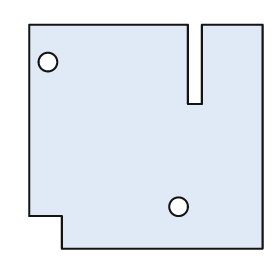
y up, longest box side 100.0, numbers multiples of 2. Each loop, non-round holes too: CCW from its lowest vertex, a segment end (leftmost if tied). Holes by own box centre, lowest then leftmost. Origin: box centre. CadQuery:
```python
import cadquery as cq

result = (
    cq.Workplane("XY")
    .moveTo(-36.0, -48.0)
    .lineTo(50.0, -48.0)
    .lineTo(50.0, 48.0)
    .lineTo(24.0, 48.0)
    .lineTo(24.0, 14.0)
    .lineTo(18.0, 14.0)
    .lineTo(18.0, 48.0)
    .lineTo(-50.0, 48.0)
    .lineTo(-50.0, -34.0)
    .lineTo(-36.0, -34.0)
    .close()
    .moveTo(14.0, -30.0)
    .circle(4.0)
    .moveTo(-42.0, 32.0)
    .circle(4.0)
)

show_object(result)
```